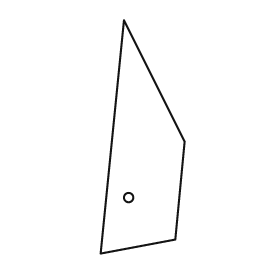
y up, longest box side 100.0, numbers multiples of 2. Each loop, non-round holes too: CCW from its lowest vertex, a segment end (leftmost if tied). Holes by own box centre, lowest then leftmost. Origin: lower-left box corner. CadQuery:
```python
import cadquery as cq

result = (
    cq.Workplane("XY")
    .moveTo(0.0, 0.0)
    .lineTo(32.0, 6.0)
    .lineTo(36.0, 48.0)
    .lineTo(10.0, 100.0)
    .close()
    .moveTo(12.0, 24.0)
    .circle(2.0)
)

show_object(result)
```